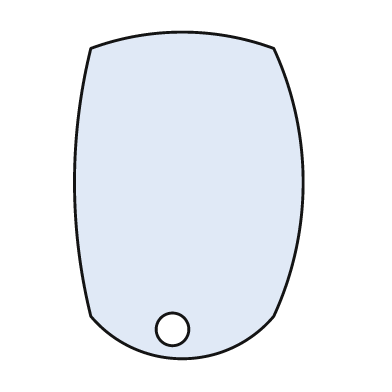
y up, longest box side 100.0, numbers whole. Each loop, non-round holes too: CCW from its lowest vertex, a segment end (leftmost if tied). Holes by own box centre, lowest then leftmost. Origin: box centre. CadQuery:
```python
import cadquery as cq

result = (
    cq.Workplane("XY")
    .moveTo(-30.0, -37.0)
    .threePointArc((-2.0, -50.0), (26.0, -37.0))
    .threePointArc((35.0, 4.0), (26.0, 45.0))
    .threePointArc((-2.0, 50.0), (-30.0, 45.0))
    .threePointArc((-35.0, 4.0), (-30.0, -37.0))
    .close()
    .moveTo(-5.0, -41.0)
    .circle(5.0)
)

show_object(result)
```